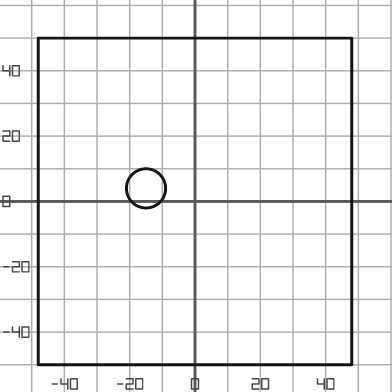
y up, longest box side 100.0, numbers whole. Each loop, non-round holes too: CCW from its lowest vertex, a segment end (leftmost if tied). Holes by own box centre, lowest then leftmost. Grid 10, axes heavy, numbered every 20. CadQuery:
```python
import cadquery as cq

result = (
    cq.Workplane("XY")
    .moveTo(-48.0, -50.0)
    .lineTo(48.0, -50.0)
    .lineTo(48.0, 50.0)
    .lineTo(-48.0, 50.0)
    .close()
    .moveTo(-15.0, 4.0)
    .circle(6.0)
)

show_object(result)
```